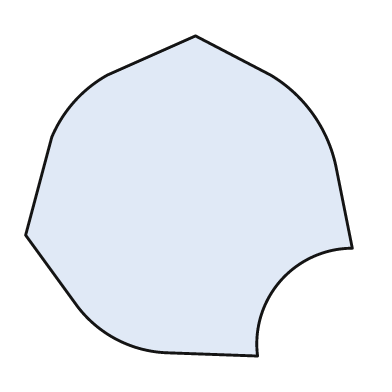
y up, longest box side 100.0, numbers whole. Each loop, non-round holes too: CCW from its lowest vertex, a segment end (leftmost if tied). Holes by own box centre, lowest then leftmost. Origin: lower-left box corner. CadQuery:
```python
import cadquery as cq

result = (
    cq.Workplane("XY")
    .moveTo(71.0, 0.0)
    .threePointArc((78.0, 23.0), (100.0, 33.0))
    .lineTo(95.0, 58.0)
    .threePointArc((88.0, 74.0), (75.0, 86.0))
    .lineTo(52.0, 98.0)
    .lineTo(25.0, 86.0)
    .threePointArc((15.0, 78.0), (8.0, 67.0))
    .lineTo(0.0, 37.0)
    .lineTo(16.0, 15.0)
    .threePointArc((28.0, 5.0), (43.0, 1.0))
    .close()
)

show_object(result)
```